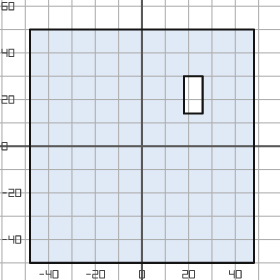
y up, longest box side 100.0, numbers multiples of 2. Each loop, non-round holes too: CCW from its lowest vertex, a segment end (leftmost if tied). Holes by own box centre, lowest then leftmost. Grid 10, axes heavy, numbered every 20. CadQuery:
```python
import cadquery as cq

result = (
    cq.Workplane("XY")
    .moveTo(-48.0, -50.0)
    .lineTo(48.0, -50.0)
    .lineTo(48.0, 50.0)
    .lineTo(-48.0, 50.0)
    .close()
    .moveTo(18.0, 14.0)
    .lineTo(26.0, 14.0)
    .lineTo(26.0, 30.0)
    .lineTo(18.0, 30.0)
    .close()
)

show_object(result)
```